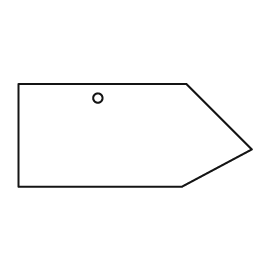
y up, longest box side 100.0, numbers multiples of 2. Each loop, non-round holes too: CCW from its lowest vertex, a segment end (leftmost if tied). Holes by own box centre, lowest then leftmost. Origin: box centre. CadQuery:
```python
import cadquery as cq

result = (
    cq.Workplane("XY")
    .moveTo(-50.0, -22.0)
    .lineTo(20.0, -22.0)
    .lineTo(50.0, -6.0)
    .lineTo(22.0, 22.0)
    .lineTo(-50.0, 22.0)
    .close()
    .moveTo(-16.0, 16.0)
    .circle(2.0)
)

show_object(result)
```